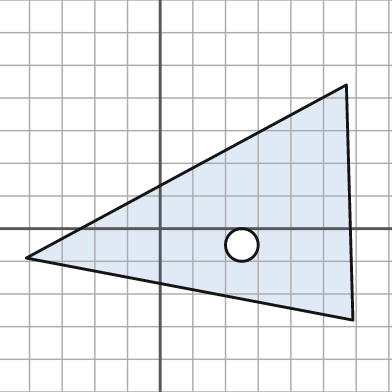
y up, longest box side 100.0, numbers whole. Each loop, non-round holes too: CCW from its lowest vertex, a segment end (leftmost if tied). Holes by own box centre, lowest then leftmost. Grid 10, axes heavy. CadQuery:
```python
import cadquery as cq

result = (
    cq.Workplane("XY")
    .moveTo(59.0, -28.0)
    .lineTo(57.0, 44.0)
    .lineTo(-41.0, -9.0)
    .close()
    .moveTo(25.0, -5.0)
    .circle(5.0)
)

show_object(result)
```